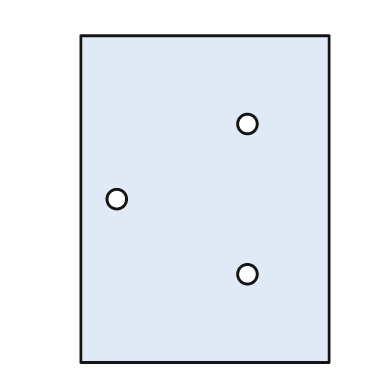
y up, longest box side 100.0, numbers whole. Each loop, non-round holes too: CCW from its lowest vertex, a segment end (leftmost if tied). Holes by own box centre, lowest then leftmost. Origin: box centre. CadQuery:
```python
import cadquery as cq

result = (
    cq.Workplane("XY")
    .moveTo(-38.0, -50.0)
    .lineTo(38.0, -50.0)
    .lineTo(38.0, 50.0)
    .lineTo(-38.0, 50.0)
    .close()
    .moveTo(13.0, -23.0)
    .circle(3.0)
    .moveTo(-27.0, 0.0)
    .circle(3.0)
    .moveTo(13.0, 23.0)
    .circle(3.0)
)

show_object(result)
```